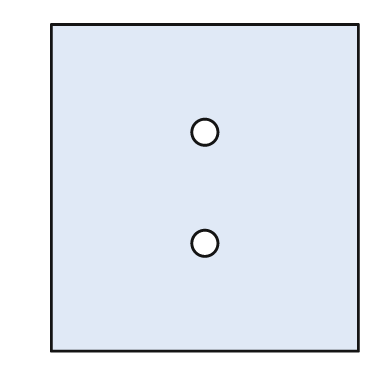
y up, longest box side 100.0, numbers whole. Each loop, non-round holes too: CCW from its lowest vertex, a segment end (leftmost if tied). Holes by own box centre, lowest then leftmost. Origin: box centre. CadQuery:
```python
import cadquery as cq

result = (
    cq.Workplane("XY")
    .moveTo(-47.0, -50.0)
    .lineTo(47.0, -50.0)
    .lineTo(47.0, 50.0)
    .lineTo(-47.0, 50.0)
    .close()
    .moveTo(0.0, -17.0)
    .circle(4.0)
    .moveTo(0.0, 17.0)
    .circle(4.0)
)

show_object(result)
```